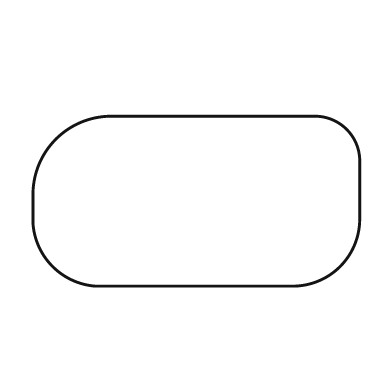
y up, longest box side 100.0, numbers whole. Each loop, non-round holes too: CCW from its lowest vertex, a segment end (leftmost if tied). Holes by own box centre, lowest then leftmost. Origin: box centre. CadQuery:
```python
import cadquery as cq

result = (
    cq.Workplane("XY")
    .moveTo(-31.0, -26.0)
    .lineTo(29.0, -26.0)
    .threePointArc((44.0, -20.0), (50.0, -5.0))
    .lineTo(50.0, 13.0)
    .threePointArc((46.0, 22.0), (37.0, 26.0))
    .lineTo(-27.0, 26.0)
    .threePointArc((-43.0, 19.0), (-50.0, 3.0))
    .lineTo(-50.0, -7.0)
    .threePointArc((-44.0, -20.0), (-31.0, -26.0))
    .close()
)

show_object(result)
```